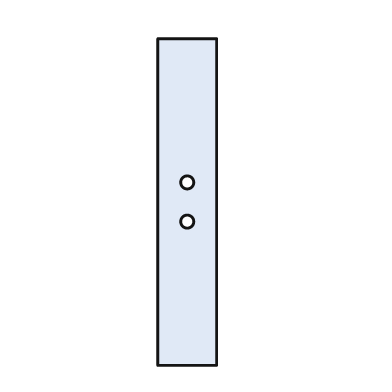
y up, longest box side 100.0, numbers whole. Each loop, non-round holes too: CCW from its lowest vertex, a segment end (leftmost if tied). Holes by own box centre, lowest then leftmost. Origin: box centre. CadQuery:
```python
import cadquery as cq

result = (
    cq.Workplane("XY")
    .moveTo(-9.0, -50.0)
    .lineTo(9.0, -50.0)
    .lineTo(9.0, 50.0)
    .lineTo(-9.0, 50.0)
    .close()
    .moveTo(0.0, -6.0)
    .circle(2.0)
    .moveTo(0.0, 6.0)
    .circle(2.0)
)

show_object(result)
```